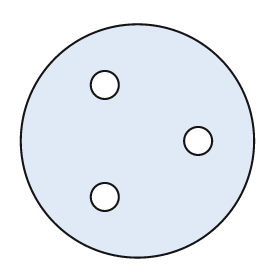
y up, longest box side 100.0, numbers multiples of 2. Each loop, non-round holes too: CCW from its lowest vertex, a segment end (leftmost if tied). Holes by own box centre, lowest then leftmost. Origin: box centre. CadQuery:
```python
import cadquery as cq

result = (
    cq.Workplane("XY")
    .moveTo(0.0, 0.0)
    .circle(50.0)
    .moveTo(-14.0, -24.0)
    .circle(6.0)
    .moveTo(26.0, 0.0)
    .circle(6.0)
    .moveTo(-14.0, 24.0)
    .circle(6.0)
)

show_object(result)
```